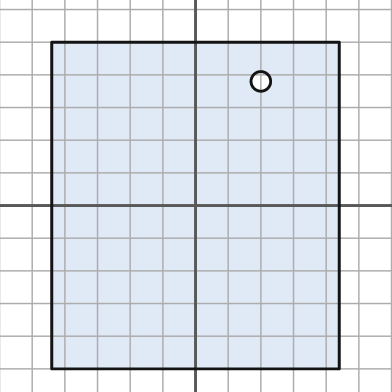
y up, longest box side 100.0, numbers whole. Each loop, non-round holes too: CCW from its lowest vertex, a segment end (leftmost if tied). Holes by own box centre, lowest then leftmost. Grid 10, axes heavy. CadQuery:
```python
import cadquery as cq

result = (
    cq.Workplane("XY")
    .moveTo(-44.0, -50.0)
    .lineTo(44.0, -50.0)
    .lineTo(44.0, 50.0)
    .lineTo(-44.0, 50.0)
    .close()
    .moveTo(20.0, 38.0)
    .circle(3.0)
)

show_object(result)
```